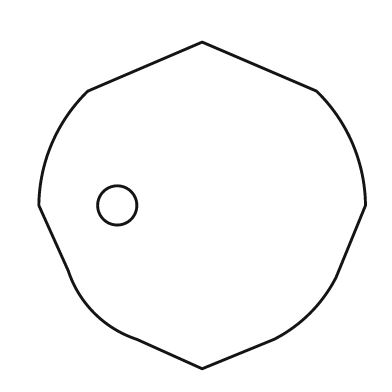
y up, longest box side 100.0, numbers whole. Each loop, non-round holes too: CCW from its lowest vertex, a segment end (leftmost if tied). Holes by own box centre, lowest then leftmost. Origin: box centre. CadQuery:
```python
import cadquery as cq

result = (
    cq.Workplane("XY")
    .moveTo(0.0, -50.0)
    .lineTo(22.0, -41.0)
    .threePointArc((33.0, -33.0), (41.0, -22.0))
    .lineTo(50.0, 0.0)
    .threePointArc((46.0, 19.0), (35.0, 35.0))
    .lineTo(0.0, 50.0)
    .lineTo(-35.0, 35.0)
    .threePointArc((-46.0, 19.0), (-50.0, 0.0))
    .lineTo(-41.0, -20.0)
    .threePointArc((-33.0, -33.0), (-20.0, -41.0))
    .close()
    .moveTo(-26.0, 0.0)
    .circle(6.0)
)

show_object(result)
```